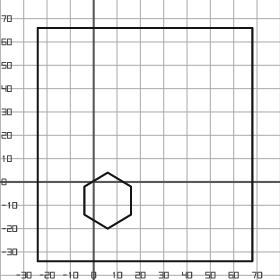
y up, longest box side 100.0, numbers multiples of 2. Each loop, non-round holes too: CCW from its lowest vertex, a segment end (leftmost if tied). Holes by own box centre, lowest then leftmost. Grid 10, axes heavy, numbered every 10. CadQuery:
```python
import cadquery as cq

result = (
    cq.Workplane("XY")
    .moveTo(-24.0, -34.0)
    .lineTo(68.0, -34.0)
    .lineTo(68.0, 66.0)
    .lineTo(-24.0, 66.0)
    .close()
    .moveTo(6.0, -20.0)
    .lineTo(16.0, -14.0)
    .lineTo(16.0, -2.0)
    .lineTo(6.0, 4.0)
    .lineTo(-4.0, -2.0)
    .lineTo(-4.0, -14.0)
    .close()
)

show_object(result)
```